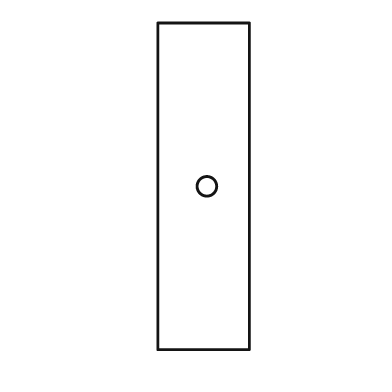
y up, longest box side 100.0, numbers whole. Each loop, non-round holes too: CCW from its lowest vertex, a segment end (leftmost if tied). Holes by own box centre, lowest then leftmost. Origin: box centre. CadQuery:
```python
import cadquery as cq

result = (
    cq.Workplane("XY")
    .moveTo(-14.0, -50.0)
    .lineTo(14.0, -50.0)
    .lineTo(14.0, 50.0)
    .lineTo(-14.0, 50.0)
    .close()
    .moveTo(1.0, 0.0)
    .circle(3.0)
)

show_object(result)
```